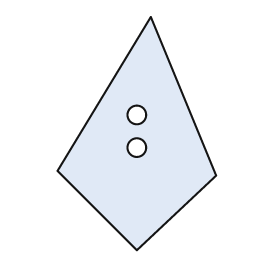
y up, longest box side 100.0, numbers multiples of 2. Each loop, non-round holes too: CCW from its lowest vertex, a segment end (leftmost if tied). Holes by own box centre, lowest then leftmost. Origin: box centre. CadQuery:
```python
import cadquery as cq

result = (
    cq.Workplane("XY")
    .moveTo(0.0, -50.0)
    .lineTo(34.0, -18.0)
    .lineTo(6.0, 50.0)
    .lineTo(-34.0, -16.0)
    .close()
    .moveTo(0.0, -6.0)
    .circle(4.0)
    .moveTo(0.0, 8.0)
    .circle(4.0)
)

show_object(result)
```